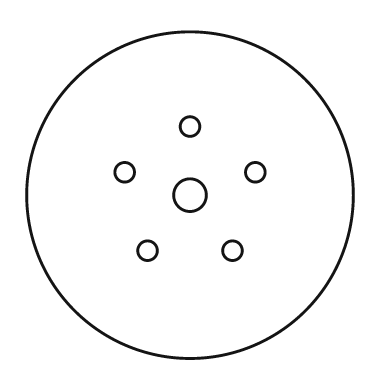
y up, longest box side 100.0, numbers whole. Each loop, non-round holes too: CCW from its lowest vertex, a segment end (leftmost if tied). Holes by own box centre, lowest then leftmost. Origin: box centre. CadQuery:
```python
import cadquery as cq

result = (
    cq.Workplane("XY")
    .moveTo(0.0, 0.0)
    .circle(50.0)
    .moveTo(-13.0, -17.0)
    .circle(3.0)
    .moveTo(13.0, -17.0)
    .circle(3.0)
    .moveTo(0.0, 0.0)
    .circle(5.0)
    .moveTo(-20.0, 7.0)
    .circle(3.0)
    .moveTo(20.0, 7.0)
    .circle(3.0)
    .moveTo(0.0, 21.0)
    .circle(3.0)
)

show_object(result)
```